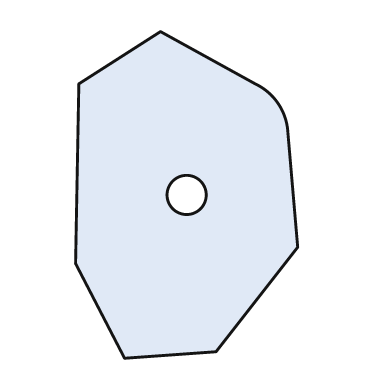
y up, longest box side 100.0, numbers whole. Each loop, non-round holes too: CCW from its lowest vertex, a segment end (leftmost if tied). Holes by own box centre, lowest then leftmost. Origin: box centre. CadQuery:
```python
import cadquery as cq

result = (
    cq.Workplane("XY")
    .moveTo(-19.0, -50.0)
    .lineTo(9.0, -48.0)
    .lineTo(34.0, -16.0)
    .lineTo(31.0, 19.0)
    .threePointArc((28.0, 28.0), (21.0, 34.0))
    .lineTo(-8.0, 50.0)
    .lineTo(-33.0, 34.0)
    .lineTo(-34.0, -21.0)
    .close()
    .moveTo(0.0, 0.0)
    .circle(6.0)
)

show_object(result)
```